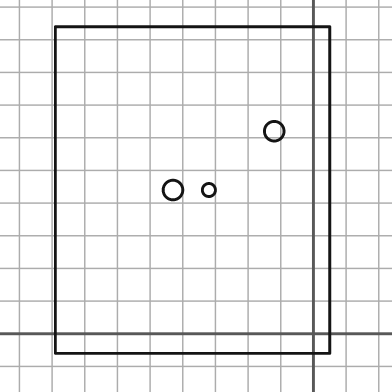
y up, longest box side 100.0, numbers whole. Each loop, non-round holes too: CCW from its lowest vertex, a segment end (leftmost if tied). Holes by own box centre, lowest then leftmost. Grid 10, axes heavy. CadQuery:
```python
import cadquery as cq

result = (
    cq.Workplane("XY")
    .moveTo(-79.0, -6.0)
    .lineTo(5.0, -6.0)
    .lineTo(5.0, 94.0)
    .lineTo(-79.0, 94.0)
    .close()
    .moveTo(-43.0, 44.0)
    .circle(3.0)
    .moveTo(-32.0, 44.0)
    .circle(2.0)
    .moveTo(-12.0, 62.0)
    .circle(3.0)
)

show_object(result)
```